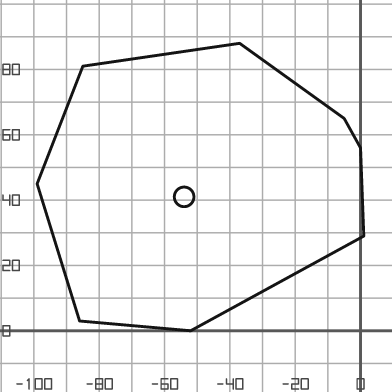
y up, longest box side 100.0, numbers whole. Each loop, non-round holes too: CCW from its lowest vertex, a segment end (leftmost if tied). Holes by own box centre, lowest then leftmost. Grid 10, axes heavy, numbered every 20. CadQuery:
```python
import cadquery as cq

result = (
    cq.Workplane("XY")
    .moveTo(-52.0, 0.0)
    .lineTo(1.0, 29.0)
    .lineTo(0.0, 56.0)
    .lineTo(-5.0, 65.0)
    .lineTo(-37.0, 88.0)
    .lineTo(-85.0, 81.0)
    .lineTo(-99.0, 45.0)
    .lineTo(-86.0, 3.0)
    .close()
    .moveTo(-54.0, 41.0)
    .circle(3.0)
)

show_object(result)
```